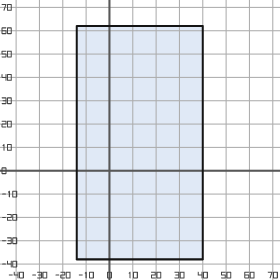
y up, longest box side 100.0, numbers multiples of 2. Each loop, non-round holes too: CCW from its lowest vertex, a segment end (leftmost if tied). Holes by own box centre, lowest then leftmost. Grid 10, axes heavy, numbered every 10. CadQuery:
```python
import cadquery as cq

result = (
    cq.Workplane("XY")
    .moveTo(-14.0, -38.0)
    .lineTo(40.0, -38.0)
    .lineTo(40.0, 62.0)
    .lineTo(-14.0, 62.0)
    .close()
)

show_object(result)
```